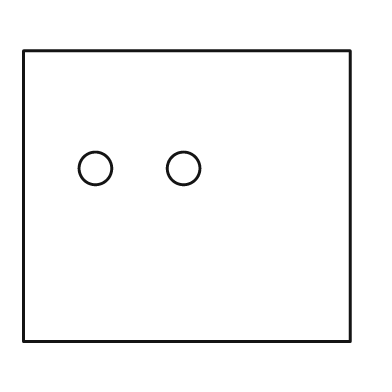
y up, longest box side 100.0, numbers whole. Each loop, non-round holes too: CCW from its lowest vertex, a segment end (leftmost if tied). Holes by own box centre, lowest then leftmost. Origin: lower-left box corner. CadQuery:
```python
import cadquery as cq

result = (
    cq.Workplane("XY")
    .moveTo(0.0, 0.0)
    .lineTo(100.0, 0.0)
    .lineTo(100.0, 89.0)
    .lineTo(0.0, 89.0)
    .close()
    .moveTo(22.0, 53.0)
    .circle(5.0)
    .moveTo(49.0, 53.0)
    .circle(5.0)
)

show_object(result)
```